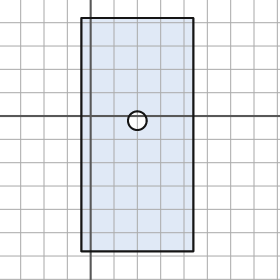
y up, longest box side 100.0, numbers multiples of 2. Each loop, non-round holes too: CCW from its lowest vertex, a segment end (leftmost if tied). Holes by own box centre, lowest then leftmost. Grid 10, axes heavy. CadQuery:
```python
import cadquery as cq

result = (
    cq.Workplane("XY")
    .moveTo(-4.0, -58.0)
    .lineTo(44.0, -58.0)
    .lineTo(44.0, 42.0)
    .lineTo(-4.0, 42.0)
    .close()
    .moveTo(20.0, -2.0)
    .circle(4.0)
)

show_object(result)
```